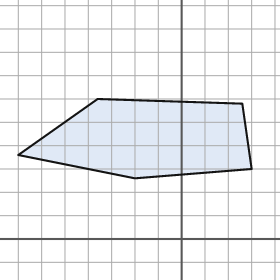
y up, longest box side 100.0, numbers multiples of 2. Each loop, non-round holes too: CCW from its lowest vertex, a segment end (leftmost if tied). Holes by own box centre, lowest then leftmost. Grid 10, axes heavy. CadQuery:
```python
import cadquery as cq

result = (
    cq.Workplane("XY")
    .moveTo(-20.0, 26.0)
    .lineTo(30.0, 30.0)
    .lineTo(26.0, 58.0)
    .lineTo(-36.0, 60.0)
    .lineTo(-70.0, 36.0)
    .close()
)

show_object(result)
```